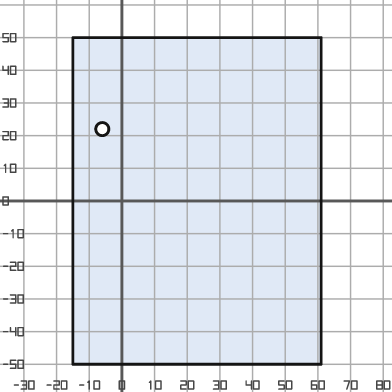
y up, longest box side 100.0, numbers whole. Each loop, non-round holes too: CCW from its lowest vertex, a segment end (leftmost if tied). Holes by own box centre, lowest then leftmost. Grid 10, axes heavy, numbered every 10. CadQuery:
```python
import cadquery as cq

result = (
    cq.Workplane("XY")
    .moveTo(-15.0, -50.0)
    .lineTo(61.0, -50.0)
    .lineTo(61.0, 50.0)
    .lineTo(-15.0, 50.0)
    .close()
    .moveTo(-6.0, 22.0)
    .circle(2.0)
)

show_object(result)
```